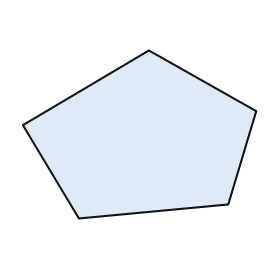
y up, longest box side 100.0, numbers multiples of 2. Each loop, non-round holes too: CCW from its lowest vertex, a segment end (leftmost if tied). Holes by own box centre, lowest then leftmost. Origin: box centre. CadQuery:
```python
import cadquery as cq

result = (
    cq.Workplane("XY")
    .moveTo(-26.0, -36.0)
    .lineTo(38.0, -30.0)
    .lineTo(50.0, 10.0)
    .lineTo(4.0, 36.0)
    .lineTo(-50.0, 4.0)
    .close()
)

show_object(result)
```